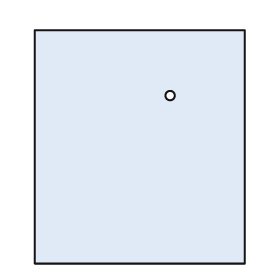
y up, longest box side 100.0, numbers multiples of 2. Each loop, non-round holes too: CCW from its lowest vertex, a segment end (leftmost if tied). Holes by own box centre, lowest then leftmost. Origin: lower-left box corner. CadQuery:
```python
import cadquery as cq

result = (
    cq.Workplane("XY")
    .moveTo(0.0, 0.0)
    .lineTo(90.0, 0.0)
    .lineTo(90.0, 100.0)
    .lineTo(0.0, 100.0)
    .close()
    .moveTo(58.0, 72.0)
    .circle(2.0)
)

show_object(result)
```